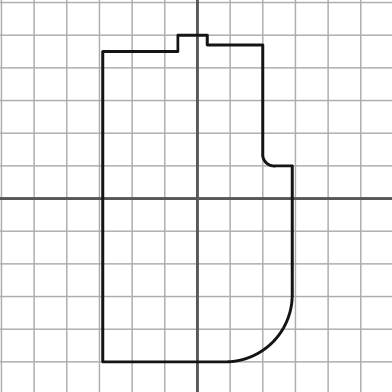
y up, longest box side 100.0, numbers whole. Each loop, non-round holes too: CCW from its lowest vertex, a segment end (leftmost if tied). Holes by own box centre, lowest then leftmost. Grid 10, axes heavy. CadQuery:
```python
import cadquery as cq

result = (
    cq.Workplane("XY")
    .moveTo(-29.0, -50.0)
    .lineTo(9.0, -50.0)
    .threePointArc((23.0, -44.0), (29.0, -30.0))
    .lineTo(29.0, 10.0)
    .lineTo(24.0, 10.0)
    .threePointArc((21.0, 11.0), (20.0, 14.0))
    .lineTo(20.0, 47.0)
    .lineTo(3.0, 47.0)
    .lineTo(3.0, 50.0)
    .lineTo(-6.0, 50.0)
    .lineTo(-6.0, 45.0)
    .lineTo(-29.0, 45.0)
    .close()
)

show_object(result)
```